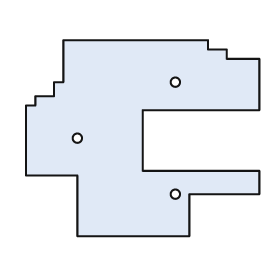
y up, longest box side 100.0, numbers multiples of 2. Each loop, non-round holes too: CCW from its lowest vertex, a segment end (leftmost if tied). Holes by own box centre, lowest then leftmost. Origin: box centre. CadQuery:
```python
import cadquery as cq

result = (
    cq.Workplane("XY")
    .moveTo(-28.0, -42.0)
    .lineTo(20.0, -42.0)
    .lineTo(20.0, -24.0)
    .lineTo(50.0, -24.0)
    .lineTo(50.0, -14.0)
    .lineTo(0.0, -14.0)
    .lineTo(0.0, 12.0)
    .lineTo(50.0, 12.0)
    .lineTo(50.0, 34.0)
    .lineTo(36.0, 34.0)
    .lineTo(36.0, 38.0)
    .lineTo(28.0, 38.0)
    .lineTo(28.0, 42.0)
    .lineTo(-34.0, 42.0)
    .lineTo(-34.0, 24.0)
    .lineTo(-38.0, 24.0)
    .lineTo(-38.0, 18.0)
    .lineTo(-46.0, 18.0)
    .lineTo(-46.0, 14.0)
    .lineTo(-50.0, 14.0)
    .lineTo(-50.0, -16.0)
    .lineTo(-28.0, -16.0)
    .close()
    .moveTo(14.0, -24.0)
    .circle(2.0)
    .moveTo(-28.0, 0.0)
    .circle(2.0)
    .moveTo(14.0, 24.0)
    .circle(2.0)
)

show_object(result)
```